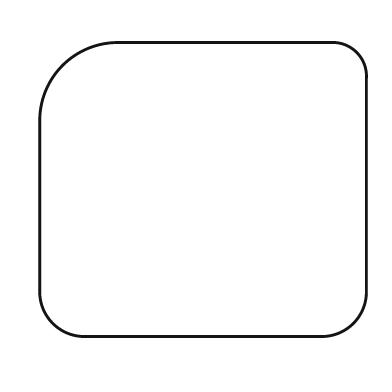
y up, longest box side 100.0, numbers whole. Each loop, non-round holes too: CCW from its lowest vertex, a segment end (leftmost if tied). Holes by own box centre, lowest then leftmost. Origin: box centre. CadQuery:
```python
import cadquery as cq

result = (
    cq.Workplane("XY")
    .moveTo(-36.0, -45.0)
    .lineTo(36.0, -45.0)
    .threePointArc((46.0, -41.0), (50.0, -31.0))
    .lineTo(50.0, 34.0)
    .threePointArc((47.0, 42.0), (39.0, 45.0))
    .lineTo(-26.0, 45.0)
    .threePointArc((-43.0, 38.0), (-50.0, 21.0))
    .lineTo(-50.0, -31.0)
    .threePointArc((-46.0, -41.0), (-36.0, -45.0))
    .close()
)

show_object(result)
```